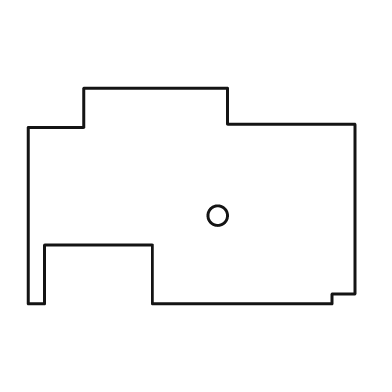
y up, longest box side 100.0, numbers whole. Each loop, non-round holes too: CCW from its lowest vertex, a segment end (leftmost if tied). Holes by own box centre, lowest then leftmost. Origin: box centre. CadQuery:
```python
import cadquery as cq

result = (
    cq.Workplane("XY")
    .moveTo(-50.0, -33.0)
    .lineTo(-45.0, -33.0)
    .lineTo(-45.0, -15.0)
    .lineTo(-12.0, -15.0)
    .lineTo(-12.0, -33.0)
    .lineTo(43.0, -33.0)
    .lineTo(43.0, -30.0)
    .lineTo(50.0, -30.0)
    .lineTo(50.0, 22.0)
    .lineTo(11.0, 22.0)
    .lineTo(11.0, 33.0)
    .lineTo(-33.0, 33.0)
    .lineTo(-33.0, 21.0)
    .lineTo(-50.0, 21.0)
    .close()
    .moveTo(8.0, -6.0)
    .circle(3.0)
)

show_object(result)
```